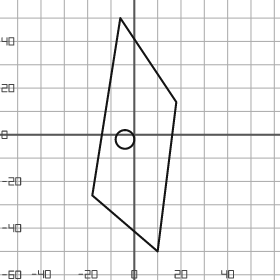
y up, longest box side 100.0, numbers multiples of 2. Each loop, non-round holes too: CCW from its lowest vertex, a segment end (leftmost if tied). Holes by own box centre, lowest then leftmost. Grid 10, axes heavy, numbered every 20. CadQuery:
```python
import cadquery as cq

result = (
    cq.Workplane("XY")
    .moveTo(10.0, -50.0)
    .lineTo(18.0, 14.0)
    .lineTo(-6.0, 50.0)
    .lineTo(-18.0, -26.0)
    .close()
    .moveTo(-4.0, -2.0)
    .circle(4.0)
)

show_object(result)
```